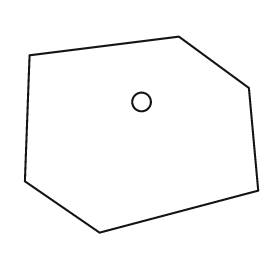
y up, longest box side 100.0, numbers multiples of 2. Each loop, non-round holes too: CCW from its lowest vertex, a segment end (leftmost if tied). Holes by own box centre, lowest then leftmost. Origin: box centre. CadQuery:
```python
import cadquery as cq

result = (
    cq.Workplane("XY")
    .moveTo(-18.0, -42.0)
    .lineTo(50.0, -24.0)
    .lineTo(46.0, 20.0)
    .lineTo(16.0, 42.0)
    .lineTo(-48.0, 34.0)
    .lineTo(-50.0, -20.0)
    .close()
    .moveTo(0.0, 14.0)
    .circle(4.0)
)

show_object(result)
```